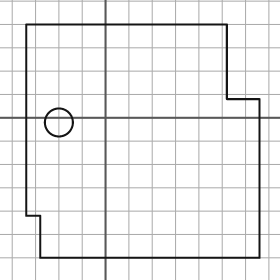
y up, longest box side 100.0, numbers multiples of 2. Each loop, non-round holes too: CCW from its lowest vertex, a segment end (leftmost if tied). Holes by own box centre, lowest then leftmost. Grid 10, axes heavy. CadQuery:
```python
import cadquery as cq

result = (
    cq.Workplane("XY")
    .moveTo(-28.0, -60.0)
    .lineTo(66.0, -60.0)
    .lineTo(66.0, 8.0)
    .lineTo(52.0, 8.0)
    .lineTo(52.0, 40.0)
    .lineTo(-34.0, 40.0)
    .lineTo(-34.0, -42.0)
    .lineTo(-28.0, -42.0)
    .close()
    .moveTo(-20.0, -2.0)
    .circle(6.0)
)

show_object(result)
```